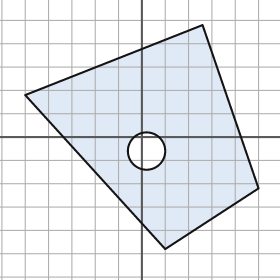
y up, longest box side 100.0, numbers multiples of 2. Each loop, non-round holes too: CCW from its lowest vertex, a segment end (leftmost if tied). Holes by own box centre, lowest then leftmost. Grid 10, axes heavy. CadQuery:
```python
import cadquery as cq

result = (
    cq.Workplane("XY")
    .moveTo(10.0, -48.0)
    .lineTo(50.0, -22.0)
    .lineTo(26.0, 48.0)
    .lineTo(-50.0, 18.0)
    .close()
    .moveTo(2.0, -6.0)
    .circle(8.0)
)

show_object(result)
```